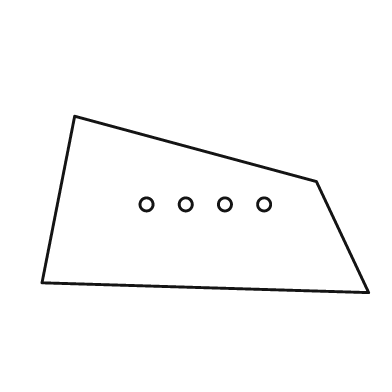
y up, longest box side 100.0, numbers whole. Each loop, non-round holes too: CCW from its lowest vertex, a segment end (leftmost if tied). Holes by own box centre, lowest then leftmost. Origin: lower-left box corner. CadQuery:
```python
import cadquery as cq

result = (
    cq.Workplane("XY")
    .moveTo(100.0, 0.0)
    .lineTo(84.0, 34.0)
    .lineTo(10.0, 54.0)
    .lineTo(0.0, 3.0)
    .close()
    .moveTo(32.0, 27.0)
    .circle(2.0)
    .moveTo(44.0, 27.0)
    .circle(2.0)
    .moveTo(56.0, 27.0)
    .circle(2.0)
    .moveTo(68.0, 27.0)
    .circle(2.0)
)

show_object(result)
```